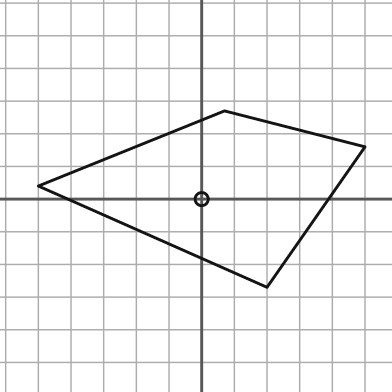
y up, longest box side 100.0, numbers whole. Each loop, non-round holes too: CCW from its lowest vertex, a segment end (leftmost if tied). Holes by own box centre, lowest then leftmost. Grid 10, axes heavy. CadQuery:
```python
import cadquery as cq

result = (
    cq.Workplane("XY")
    .moveTo(20.0, -27.0)
    .lineTo(50.0, 16.0)
    .lineTo(7.0, 27.0)
    .lineTo(-50.0, 4.0)
    .close()
    .moveTo(0.0, 0.0)
    .circle(2.0)
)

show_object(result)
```